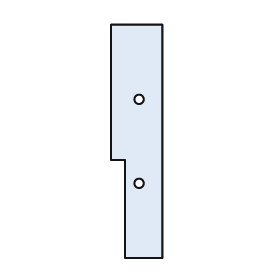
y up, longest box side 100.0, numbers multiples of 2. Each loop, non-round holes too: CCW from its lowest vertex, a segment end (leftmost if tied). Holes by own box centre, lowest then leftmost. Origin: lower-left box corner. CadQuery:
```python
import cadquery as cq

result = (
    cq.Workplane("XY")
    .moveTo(6.0, 0.0)
    .lineTo(22.0, 0.0)
    .lineTo(22.0, 100.0)
    .lineTo(0.0, 100.0)
    .lineTo(0.0, 42.0)
    .lineTo(6.0, 42.0)
    .close()
    .moveTo(12.0, 32.0)
    .circle(2.0)
    .moveTo(12.0, 68.0)
    .circle(2.0)
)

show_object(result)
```